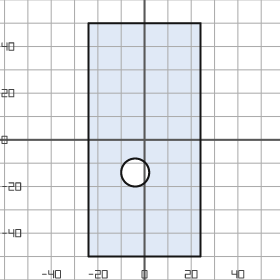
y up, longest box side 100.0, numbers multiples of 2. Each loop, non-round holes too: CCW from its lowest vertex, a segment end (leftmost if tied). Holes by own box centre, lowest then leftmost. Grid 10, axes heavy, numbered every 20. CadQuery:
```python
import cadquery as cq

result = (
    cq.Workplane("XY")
    .moveTo(-24.0, -50.0)
    .lineTo(24.0, -50.0)
    .lineTo(24.0, 50.0)
    .lineTo(-24.0, 50.0)
    .close()
    .moveTo(-4.0, -14.0)
    .circle(6.0)
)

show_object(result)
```